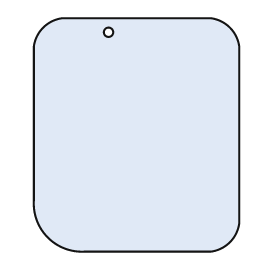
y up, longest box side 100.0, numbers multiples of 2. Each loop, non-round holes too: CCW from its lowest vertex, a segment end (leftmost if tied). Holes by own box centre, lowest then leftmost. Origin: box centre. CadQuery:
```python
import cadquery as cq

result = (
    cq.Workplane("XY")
    .moveTo(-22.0, -50.0)
    .lineTo(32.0, -50.0)
    .threePointArc((40.0, -46.0), (44.0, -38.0))
    .lineTo(44.0, 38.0)
    .threePointArc((40.0, 46.0), (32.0, 50.0))
    .lineTo(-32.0, 50.0)
    .threePointArc((-40.0, 46.0), (-44.0, 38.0))
    .lineTo(-44.0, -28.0)
    .threePointArc((-38.0, -44.0), (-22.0, -50.0))
    .close()
    .moveTo(-12.0, 44.0)
    .circle(2.0)
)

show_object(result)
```